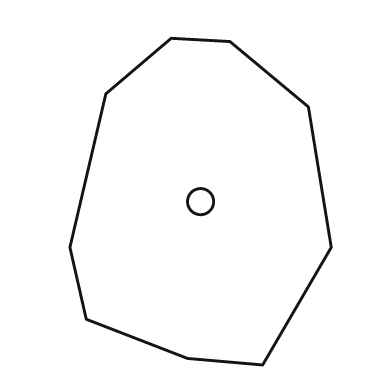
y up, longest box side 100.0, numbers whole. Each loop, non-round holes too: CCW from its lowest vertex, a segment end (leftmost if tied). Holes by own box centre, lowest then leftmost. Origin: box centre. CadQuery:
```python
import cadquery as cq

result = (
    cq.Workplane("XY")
    .moveTo(19.0, -50.0)
    .lineTo(40.0, -14.0)
    .lineTo(33.0, 29.0)
    .lineTo(9.0, 49.0)
    .lineTo(-9.0, 50.0)
    .lineTo(-29.0, 33.0)
    .lineTo(-40.0, -14.0)
    .lineTo(-35.0, -36.0)
    .lineTo(-4.0, -48.0)
    .close()
    .moveTo(0.0, 0.0)
    .circle(4.0)
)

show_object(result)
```